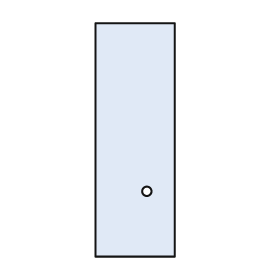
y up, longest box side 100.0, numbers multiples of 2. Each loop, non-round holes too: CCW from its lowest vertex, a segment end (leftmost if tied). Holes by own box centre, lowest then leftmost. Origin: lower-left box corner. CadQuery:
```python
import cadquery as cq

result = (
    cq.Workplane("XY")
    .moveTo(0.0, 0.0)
    .lineTo(34.0, 0.0)
    .lineTo(34.0, 100.0)
    .lineTo(0.0, 100.0)
    .close()
    .moveTo(22.0, 28.0)
    .circle(2.0)
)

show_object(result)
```